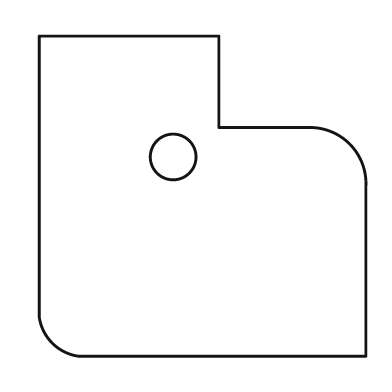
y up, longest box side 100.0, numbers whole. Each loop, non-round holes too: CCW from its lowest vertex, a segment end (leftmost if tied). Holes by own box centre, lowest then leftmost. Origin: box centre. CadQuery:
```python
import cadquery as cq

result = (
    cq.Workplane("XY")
    .moveTo(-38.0, -49.0)
    .lineTo(50.0, -49.0)
    .lineTo(50.0, 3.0)
    .threePointArc((45.0, 16.0), (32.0, 21.0))
    .lineTo(5.0, 21.0)
    .lineTo(5.0, 49.0)
    .lineTo(-50.0, 49.0)
    .lineTo(-50.0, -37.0)
    .threePointArc((-46.0, -45.0), (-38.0, -49.0))
    .close()
    .moveTo(-9.0, 12.0)
    .circle(7.0)
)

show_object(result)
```